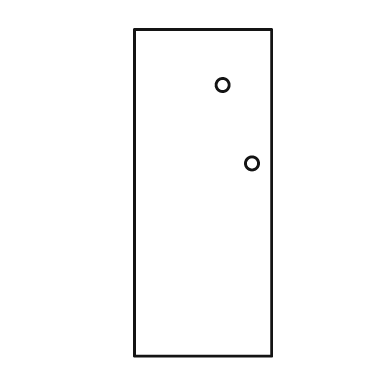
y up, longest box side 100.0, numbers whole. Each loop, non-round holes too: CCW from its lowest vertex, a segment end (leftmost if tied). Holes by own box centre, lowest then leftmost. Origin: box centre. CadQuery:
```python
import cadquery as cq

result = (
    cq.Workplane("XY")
    .moveTo(-21.0, -50.0)
    .lineTo(21.0, -50.0)
    .lineTo(21.0, 50.0)
    .lineTo(-21.0, 50.0)
    .close()
    .moveTo(15.0, 9.0)
    .circle(2.0)
    .moveTo(6.0, 33.0)
    .circle(2.0)
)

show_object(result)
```